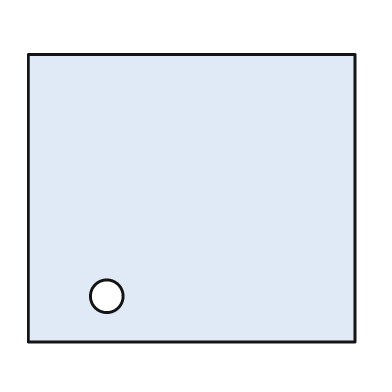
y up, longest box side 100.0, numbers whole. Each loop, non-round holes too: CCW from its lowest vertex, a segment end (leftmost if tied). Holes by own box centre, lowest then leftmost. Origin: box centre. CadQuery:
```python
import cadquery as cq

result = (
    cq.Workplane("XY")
    .moveTo(-50.0, -44.0)
    .lineTo(50.0, -44.0)
    .lineTo(50.0, 44.0)
    .lineTo(-50.0, 44.0)
    .close()
    .moveTo(-26.0, -30.0)
    .circle(5.0)
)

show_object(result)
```